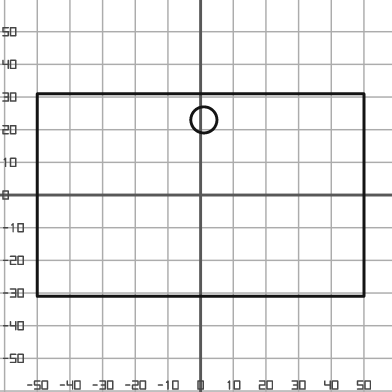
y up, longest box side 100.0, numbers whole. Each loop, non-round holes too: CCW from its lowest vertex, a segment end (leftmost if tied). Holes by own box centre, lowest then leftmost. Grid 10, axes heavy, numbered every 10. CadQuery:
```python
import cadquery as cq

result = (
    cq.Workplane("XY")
    .moveTo(-50.0, -31.0)
    .lineTo(50.0, -31.0)
    .lineTo(50.0, 31.0)
    .lineTo(-50.0, 31.0)
    .close()
    .moveTo(1.0, 23.0)
    .circle(4.0)
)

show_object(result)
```